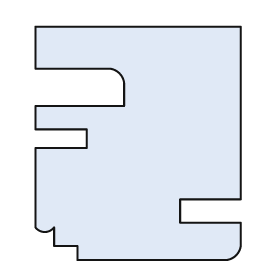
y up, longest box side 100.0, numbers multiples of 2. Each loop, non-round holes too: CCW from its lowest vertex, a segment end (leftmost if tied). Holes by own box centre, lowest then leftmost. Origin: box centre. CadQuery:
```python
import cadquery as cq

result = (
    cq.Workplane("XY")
    .moveTo(-26.0, -50.0)
    .lineTo(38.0, -50.0)
    .threePointArc((42.0, -48.0), (44.0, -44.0))
    .lineTo(44.0, -34.0)
    .lineTo(18.0, -34.0)
    .lineTo(18.0, -24.0)
    .lineTo(44.0, -24.0)
    .lineTo(44.0, 50.0)
    .lineTo(-44.0, 50.0)
    .lineTo(-44.0, 32.0)
    .lineTo(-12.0, 32.0)
    .threePointArc((-8.0, 30.0), (-6.0, 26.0))
    .lineTo(-6.0, 16.0)
    .lineTo(-44.0, 16.0)
    .lineTo(-44.0, 6.0)
    .lineTo(-22.0, 6.0)
    .lineTo(-22.0, -2.0)
    .lineTo(-44.0, -2.0)
    .lineTo(-44.0, -36.0)
    .threePointArc((-40.0, -38.0), (-36.0, -36.0))
    .lineTo(-36.0, -44.0)
    .lineTo(-26.0, -44.0)
    .close()
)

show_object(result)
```